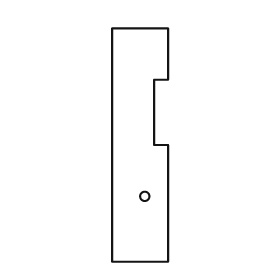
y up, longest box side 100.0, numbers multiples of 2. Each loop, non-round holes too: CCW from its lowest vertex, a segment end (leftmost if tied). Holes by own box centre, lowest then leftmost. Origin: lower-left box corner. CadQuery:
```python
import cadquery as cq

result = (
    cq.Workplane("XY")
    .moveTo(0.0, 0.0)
    .lineTo(24.0, 0.0)
    .lineTo(24.0, 50.0)
    .lineTo(18.0, 50.0)
    .lineTo(18.0, 78.0)
    .lineTo(24.0, 78.0)
    .lineTo(24.0, 100.0)
    .lineTo(0.0, 100.0)
    .close()
    .moveTo(14.0, 28.0)
    .circle(2.0)
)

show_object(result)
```